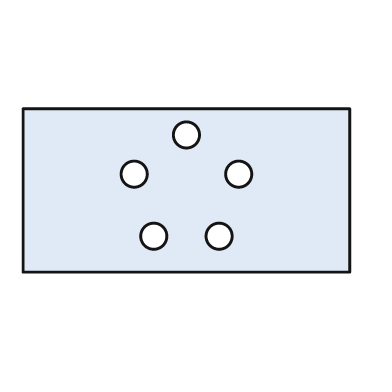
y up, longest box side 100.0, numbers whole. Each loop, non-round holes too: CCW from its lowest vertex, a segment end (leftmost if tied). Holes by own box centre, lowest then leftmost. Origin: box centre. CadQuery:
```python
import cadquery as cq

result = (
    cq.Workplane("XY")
    .moveTo(-50.0, -25.0)
    .lineTo(50.0, -25.0)
    .lineTo(50.0, 25.0)
    .lineTo(-50.0, 25.0)
    .close()
    .moveTo(-10.0, -14.0)
    .circle(4.0)
    .moveTo(10.0, -14.0)
    .circle(4.0)
    .moveTo(-16.0, 5.0)
    .circle(4.0)
    .moveTo(16.0, 5.0)
    .circle(4.0)
    .moveTo(0.0, 17.0)
    .circle(4.0)
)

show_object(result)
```